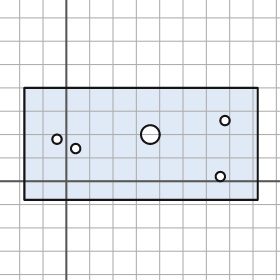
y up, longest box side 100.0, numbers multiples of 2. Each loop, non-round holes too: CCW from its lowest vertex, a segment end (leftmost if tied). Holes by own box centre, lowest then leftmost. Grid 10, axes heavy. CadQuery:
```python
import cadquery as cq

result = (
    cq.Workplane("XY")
    .moveTo(-18.0, -8.0)
    .lineTo(82.0, -8.0)
    .lineTo(82.0, 40.0)
    .lineTo(-18.0, 40.0)
    .close()
    .moveTo(66.0, 2.0)
    .circle(2.0)
    .moveTo(4.0, 14.0)
    .circle(2.0)
    .moveTo(-4.0, 18.0)
    .circle(2.0)
    .moveTo(36.0, 20.0)
    .circle(4.0)
    .moveTo(68.0, 26.0)
    .circle(2.0)
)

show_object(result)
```